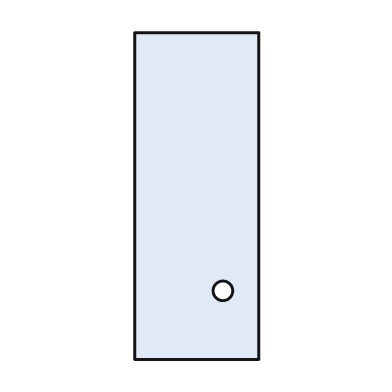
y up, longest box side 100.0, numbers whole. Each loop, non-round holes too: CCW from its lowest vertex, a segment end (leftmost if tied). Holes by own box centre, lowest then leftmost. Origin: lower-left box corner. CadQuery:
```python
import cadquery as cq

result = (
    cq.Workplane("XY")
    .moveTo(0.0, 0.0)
    .lineTo(38.0, 0.0)
    .lineTo(38.0, 100.0)
    .lineTo(0.0, 100.0)
    .close()
    .moveTo(27.0, 21.0)
    .circle(3.0)
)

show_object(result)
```